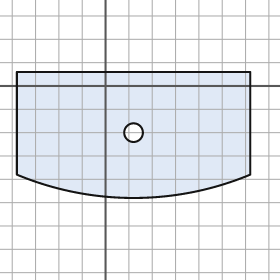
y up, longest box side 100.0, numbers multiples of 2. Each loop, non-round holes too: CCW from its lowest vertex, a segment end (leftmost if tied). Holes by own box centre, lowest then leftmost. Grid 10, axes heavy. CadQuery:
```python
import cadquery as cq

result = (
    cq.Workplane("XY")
    .moveTo(-38.0, -38.0)
    .threePointArc((12.0, -48.0), (62.0, -38.0))
    .lineTo(62.0, 6.0)
    .lineTo(-38.0, 6.0)
    .close()
    .moveTo(12.0, -20.0)
    .circle(4.0)
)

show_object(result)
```